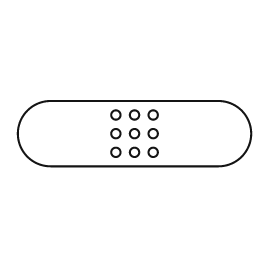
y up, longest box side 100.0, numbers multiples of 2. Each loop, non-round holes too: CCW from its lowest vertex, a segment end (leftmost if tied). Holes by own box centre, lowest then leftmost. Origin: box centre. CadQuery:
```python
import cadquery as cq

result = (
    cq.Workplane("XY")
    .moveTo(-36.0, -14.0)
    .lineTo(36.0, -14.0)
    .threePointArc((50.0, 0.0), (36.0, 14.0))
    .lineTo(-36.0, 14.0)
    .threePointArc((-50.0, 0.0), (-36.0, -14.0))
    .close()
    .moveTo(-8.0, -8.0)
    .circle(2.0)
    .moveTo(0.0, -8.0)
    .circle(2.0)
    .moveTo(8.0, -8.0)
    .circle(2.0)
    .moveTo(-8.0, 0.0)
    .circle(2.0)
    .moveTo(0.0, 0.0)
    .circle(2.0)
    .moveTo(8.0, 0.0)
    .circle(2.0)
    .moveTo(-8.0, 8.0)
    .circle(2.0)
    .moveTo(0.0, 8.0)
    .circle(2.0)
    .moveTo(8.0, 8.0)
    .circle(2.0)
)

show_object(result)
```